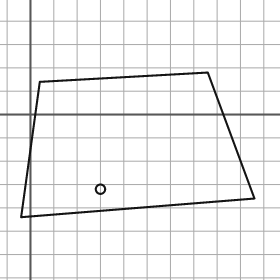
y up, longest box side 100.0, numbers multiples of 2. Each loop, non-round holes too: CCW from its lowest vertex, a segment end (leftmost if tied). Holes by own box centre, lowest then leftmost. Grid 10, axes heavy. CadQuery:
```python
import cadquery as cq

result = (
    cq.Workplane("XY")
    .moveTo(-4.0, -44.0)
    .lineTo(96.0, -36.0)
    .lineTo(76.0, 18.0)
    .lineTo(4.0, 14.0)
    .close()
    .moveTo(30.0, -32.0)
    .circle(2.0)
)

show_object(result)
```